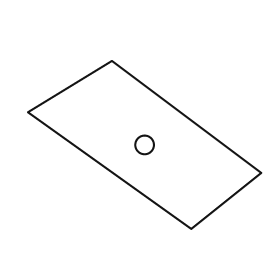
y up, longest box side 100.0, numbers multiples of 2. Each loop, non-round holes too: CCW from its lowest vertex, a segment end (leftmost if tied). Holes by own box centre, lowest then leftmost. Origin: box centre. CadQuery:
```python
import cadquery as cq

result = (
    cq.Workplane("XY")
    .moveTo(20.0, -36.0)
    .lineTo(50.0, -12.0)
    .lineTo(-14.0, 36.0)
    .lineTo(-50.0, 14.0)
    .close()
    .moveTo(0.0, 0.0)
    .circle(4.0)
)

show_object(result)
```